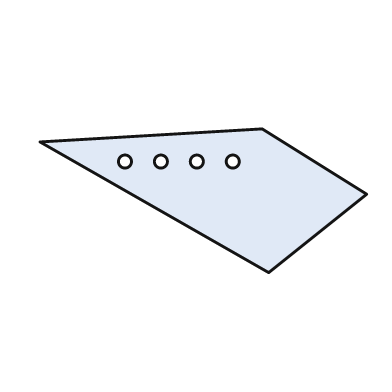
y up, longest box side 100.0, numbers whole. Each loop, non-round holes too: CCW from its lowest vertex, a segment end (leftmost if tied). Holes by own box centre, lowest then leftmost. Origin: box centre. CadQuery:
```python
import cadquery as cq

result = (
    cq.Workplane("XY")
    .moveTo(20.0, -22.0)
    .lineTo(50.0, 2.0)
    .lineTo(18.0, 22.0)
    .lineTo(-50.0, 18.0)
    .close()
    .moveTo(-24.0, 12.0)
    .circle(2.0)
    .moveTo(-13.0, 12.0)
    .circle(2.0)
    .moveTo(-2.0, 12.0)
    .circle(2.0)
    .moveTo(9.0, 12.0)
    .circle(2.0)
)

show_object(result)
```